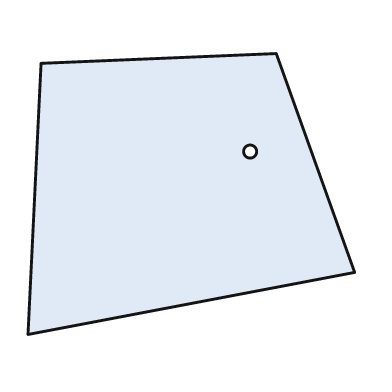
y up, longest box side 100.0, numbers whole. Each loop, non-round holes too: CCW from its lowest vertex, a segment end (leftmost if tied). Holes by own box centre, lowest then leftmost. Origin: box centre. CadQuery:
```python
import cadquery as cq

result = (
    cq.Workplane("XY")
    .moveTo(-50.0, -43.0)
    .lineTo(50.0, -24.0)
    .lineTo(26.0, 43.0)
    .lineTo(-46.0, 40.0)
    .close()
    .moveTo(18.0, 13.0)
    .circle(2.0)
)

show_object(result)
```